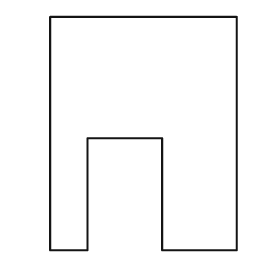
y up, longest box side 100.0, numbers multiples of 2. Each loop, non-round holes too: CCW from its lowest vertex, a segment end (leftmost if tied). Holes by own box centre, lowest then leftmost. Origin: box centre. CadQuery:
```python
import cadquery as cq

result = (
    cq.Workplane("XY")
    .moveTo(-40.0, -50.0)
    .lineTo(-24.0, -50.0)
    .lineTo(-24.0, -2.0)
    .lineTo(8.0, -2.0)
    .lineTo(8.0, -50.0)
    .lineTo(40.0, -50.0)
    .lineTo(40.0, 50.0)
    .lineTo(-40.0, 50.0)
    .close()
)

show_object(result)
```